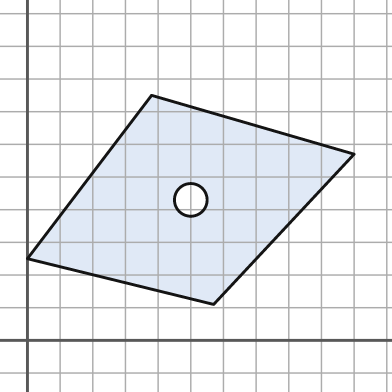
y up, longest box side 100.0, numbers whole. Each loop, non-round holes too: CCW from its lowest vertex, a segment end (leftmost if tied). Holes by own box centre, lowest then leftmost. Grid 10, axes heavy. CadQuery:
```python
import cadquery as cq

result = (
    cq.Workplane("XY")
    .moveTo(57.0, 11.0)
    .lineTo(100.0, 57.0)
    .lineTo(38.0, 75.0)
    .lineTo(0.0, 25.0)
    .close()
    .moveTo(50.0, 43.0)
    .circle(5.0)
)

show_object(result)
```